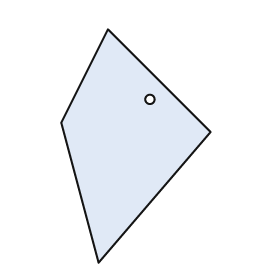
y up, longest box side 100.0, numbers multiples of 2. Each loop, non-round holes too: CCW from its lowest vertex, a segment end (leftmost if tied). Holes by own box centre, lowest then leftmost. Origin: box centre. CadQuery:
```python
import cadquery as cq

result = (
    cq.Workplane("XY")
    .moveTo(-16.0, -50.0)
    .lineTo(32.0, 6.0)
    .lineTo(-12.0, 50.0)
    .lineTo(-32.0, 10.0)
    .close()
    .moveTo(6.0, 20.0)
    .circle(2.0)
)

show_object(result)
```